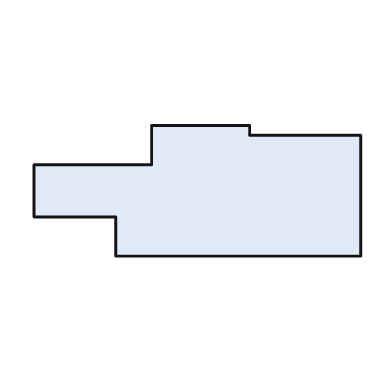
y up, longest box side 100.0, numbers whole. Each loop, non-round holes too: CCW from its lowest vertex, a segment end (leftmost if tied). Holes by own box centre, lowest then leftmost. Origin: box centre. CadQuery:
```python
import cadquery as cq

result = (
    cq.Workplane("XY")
    .moveTo(-25.0, -20.0)
    .lineTo(50.0, -20.0)
    .lineTo(50.0, 17.0)
    .lineTo(16.0, 17.0)
    .lineTo(16.0, 20.0)
    .lineTo(-14.0, 20.0)
    .lineTo(-14.0, 8.0)
    .lineTo(-50.0, 8.0)
    .lineTo(-50.0, -8.0)
    .lineTo(-25.0, -8.0)
    .close()
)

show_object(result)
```